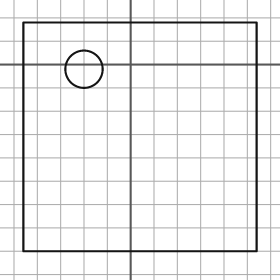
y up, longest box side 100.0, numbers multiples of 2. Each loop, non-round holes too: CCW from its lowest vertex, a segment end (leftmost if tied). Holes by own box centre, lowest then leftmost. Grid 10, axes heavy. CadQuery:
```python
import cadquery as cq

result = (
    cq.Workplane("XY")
    .moveTo(-46.0, -80.0)
    .lineTo(54.0, -80.0)
    .lineTo(54.0, 18.0)
    .lineTo(-46.0, 18.0)
    .close()
    .moveTo(-20.0, -2.0)
    .circle(8.0)
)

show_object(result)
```